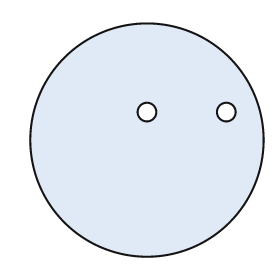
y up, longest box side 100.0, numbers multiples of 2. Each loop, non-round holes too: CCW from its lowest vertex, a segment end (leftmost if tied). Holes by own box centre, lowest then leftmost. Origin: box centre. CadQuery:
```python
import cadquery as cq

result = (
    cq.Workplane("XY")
    .moveTo(0.0, 0.0)
    .circle(50.0)
    .moveTo(0.0, 12.0)
    .circle(4.0)
    .moveTo(34.0, 12.0)
    .circle(4.0)
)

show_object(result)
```